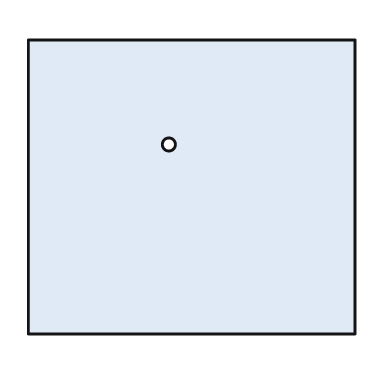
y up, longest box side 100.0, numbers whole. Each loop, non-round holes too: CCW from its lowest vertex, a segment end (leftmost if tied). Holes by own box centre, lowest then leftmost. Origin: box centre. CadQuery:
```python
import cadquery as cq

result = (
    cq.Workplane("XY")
    .moveTo(-50.0, -45.0)
    .lineTo(50.0, -45.0)
    .lineTo(50.0, 45.0)
    .lineTo(-50.0, 45.0)
    .close()
    .moveTo(-7.0, 13.0)
    .circle(2.0)
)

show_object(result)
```